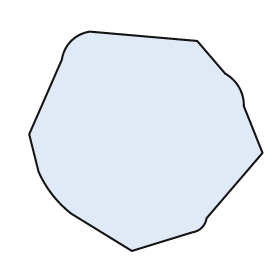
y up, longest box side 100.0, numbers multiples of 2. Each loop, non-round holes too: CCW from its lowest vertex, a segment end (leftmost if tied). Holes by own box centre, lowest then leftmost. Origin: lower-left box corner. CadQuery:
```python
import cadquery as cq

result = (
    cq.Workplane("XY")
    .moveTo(44.0, 0.0)
    .lineTo(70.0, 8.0)
    .threePointArc((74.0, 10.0), (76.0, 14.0))
    .lineTo(100.0, 42.0)
    .lineTo(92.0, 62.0)
    .threePointArc((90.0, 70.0), (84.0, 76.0))
    .lineTo(72.0, 90.0)
    .lineTo(26.0, 94.0)
    .threePointArc((18.0, 90.0), (14.0, 82.0))
    .lineTo(0.0, 50.0)
    .lineTo(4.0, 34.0)
    .threePointArc((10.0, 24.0), (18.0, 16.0))
    .close()
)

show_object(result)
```